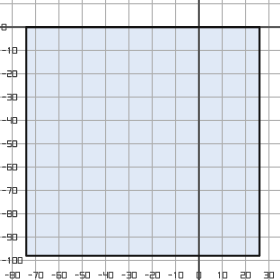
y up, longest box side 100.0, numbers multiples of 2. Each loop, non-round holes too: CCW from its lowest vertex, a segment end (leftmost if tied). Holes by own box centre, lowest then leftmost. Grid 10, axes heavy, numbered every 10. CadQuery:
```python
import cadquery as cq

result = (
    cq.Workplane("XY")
    .moveTo(-74.0, -98.0)
    .lineTo(26.0, -98.0)
    .lineTo(26.0, 0.0)
    .lineTo(-74.0, 0.0)
    .close()
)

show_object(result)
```